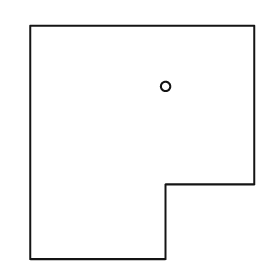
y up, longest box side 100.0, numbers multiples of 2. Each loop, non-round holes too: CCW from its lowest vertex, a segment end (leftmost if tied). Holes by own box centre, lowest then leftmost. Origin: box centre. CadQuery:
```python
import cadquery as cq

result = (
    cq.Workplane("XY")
    .moveTo(-48.0, -50.0)
    .lineTo(10.0, -50.0)
    .lineTo(10.0, -18.0)
    .lineTo(48.0, -18.0)
    .lineTo(48.0, 50.0)
    .lineTo(-48.0, 50.0)
    .close()
    .moveTo(10.0, 24.0)
    .circle(2.0)
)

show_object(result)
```